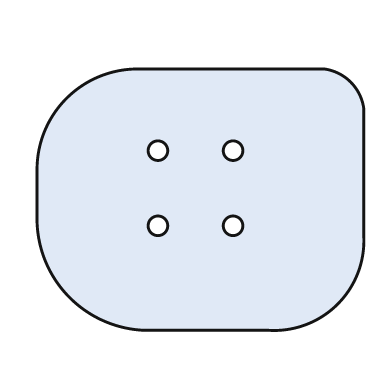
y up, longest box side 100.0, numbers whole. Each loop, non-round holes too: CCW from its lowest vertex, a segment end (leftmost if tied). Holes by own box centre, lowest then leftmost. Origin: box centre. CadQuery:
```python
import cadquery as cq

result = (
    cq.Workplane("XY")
    .moveTo(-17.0, -40.0)
    .lineTo(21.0, -40.0)
    .threePointArc((42.0, -32.0), (50.0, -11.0))
    .lineTo(50.0, 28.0)
    .threePointArc((46.0, 36.0), (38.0, 40.0))
    .lineTo(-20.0, 40.0)
    .threePointArc((-41.0, 31.0), (-50.0, 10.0))
    .lineTo(-50.0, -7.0)
    .threePointArc((-40.0, -30.0), (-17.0, -40.0))
    .close()
    .moveTo(-13.0, -8.0)
    .circle(3.0)
    .moveTo(10.0, -8.0)
    .circle(3.0)
    .moveTo(-13.0, 15.0)
    .circle(3.0)
    .moveTo(10.0, 15.0)
    .circle(3.0)
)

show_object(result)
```